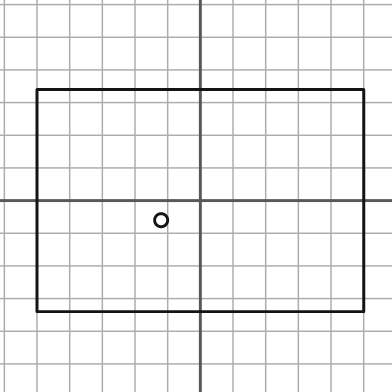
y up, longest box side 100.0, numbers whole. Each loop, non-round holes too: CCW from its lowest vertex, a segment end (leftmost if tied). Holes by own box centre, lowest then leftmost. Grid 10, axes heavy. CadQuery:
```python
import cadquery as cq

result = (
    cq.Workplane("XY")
    .moveTo(-50.0, -34.0)
    .lineTo(50.0, -34.0)
    .lineTo(50.0, 34.0)
    .lineTo(-50.0, 34.0)
    .close()
    .moveTo(-12.0, -6.0)
    .circle(2.0)
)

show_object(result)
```